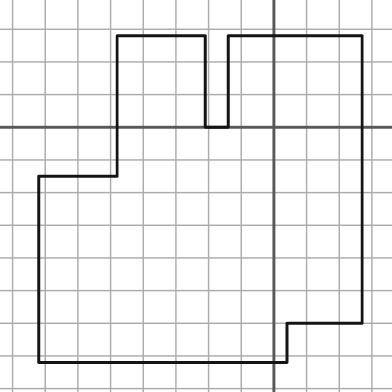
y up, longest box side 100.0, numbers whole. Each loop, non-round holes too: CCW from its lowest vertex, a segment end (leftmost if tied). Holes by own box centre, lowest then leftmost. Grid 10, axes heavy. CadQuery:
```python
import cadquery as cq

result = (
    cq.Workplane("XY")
    .moveTo(-72.0, -72.0)
    .lineTo(4.0, -72.0)
    .lineTo(4.0, -60.0)
    .lineTo(27.0, -60.0)
    .lineTo(27.0, 28.0)
    .lineTo(-14.0, 28.0)
    .lineTo(-14.0, 0.0)
    .lineTo(-21.0, 0.0)
    .lineTo(-21.0, 28.0)
    .lineTo(-48.0, 28.0)
    .lineTo(-48.0, -15.0)
    .lineTo(-72.0, -15.0)
    .close()
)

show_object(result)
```